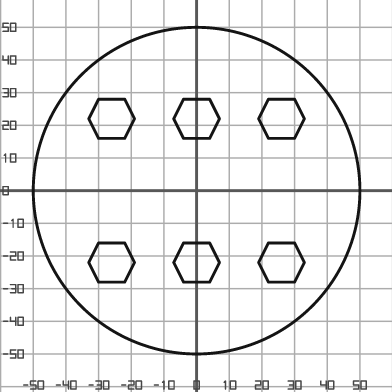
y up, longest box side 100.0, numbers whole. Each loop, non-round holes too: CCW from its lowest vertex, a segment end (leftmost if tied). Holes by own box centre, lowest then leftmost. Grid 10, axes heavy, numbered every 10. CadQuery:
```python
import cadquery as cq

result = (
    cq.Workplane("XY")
    .moveTo(0.0, 0.0)
    .circle(50.0)
    .moveTo(-30.0, -28.0)
    .lineTo(-22.0, -28.0)
    .lineTo(-19.0, -22.0)
    .lineTo(-22.0, -16.0)
    .lineTo(-30.0, -16.0)
    .lineTo(-33.0, -22.0)
    .close()
    .moveTo(-4.0, -28.0)
    .lineTo(4.0, -28.0)
    .lineTo(7.0, -22.0)
    .lineTo(4.0, -16.0)
    .lineTo(-4.0, -16.0)
    .lineTo(-7.0, -22.0)
    .close()
    .moveTo(22.0, -28.0)
    .lineTo(30.0, -28.0)
    .lineTo(33.0, -22.0)
    .lineTo(30.0, -16.0)
    .lineTo(22.0, -16.0)
    .lineTo(19.0, -22.0)
    .close()
    .moveTo(-30.0, 16.0)
    .lineTo(-22.0, 16.0)
    .lineTo(-19.0, 22.0)
    .lineTo(-22.0, 28.0)
    .lineTo(-30.0, 28.0)
    .lineTo(-33.0, 22.0)
    .close()
    .moveTo(-4.0, 16.0)
    .lineTo(4.0, 16.0)
    .lineTo(7.0, 22.0)
    .lineTo(4.0, 28.0)
    .lineTo(-4.0, 28.0)
    .lineTo(-7.0, 22.0)
    .close()
    .moveTo(22.0, 16.0)
    .lineTo(30.0, 16.0)
    .lineTo(33.0, 22.0)
    .lineTo(30.0, 28.0)
    .lineTo(22.0, 28.0)
    .lineTo(19.0, 22.0)
    .close()
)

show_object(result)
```